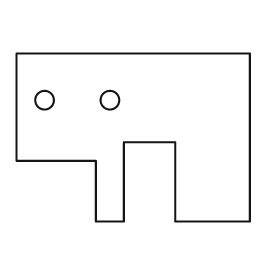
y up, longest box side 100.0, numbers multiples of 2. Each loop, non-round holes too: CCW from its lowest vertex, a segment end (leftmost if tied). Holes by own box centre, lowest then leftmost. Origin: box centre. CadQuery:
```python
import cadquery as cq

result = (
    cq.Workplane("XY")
    .moveTo(-16.0, -36.0)
    .lineTo(-4.0, -36.0)
    .lineTo(-4.0, -2.0)
    .lineTo(18.0, -2.0)
    .lineTo(18.0, -36.0)
    .lineTo(50.0, -36.0)
    .lineTo(50.0, 36.0)
    .lineTo(-50.0, 36.0)
    .lineTo(-50.0, -10.0)
    .lineTo(-16.0, -10.0)
    .close()
    .moveTo(-38.0, 16.0)
    .circle(4.0)
    .moveTo(-10.0, 16.0)
    .circle(4.0)
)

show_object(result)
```